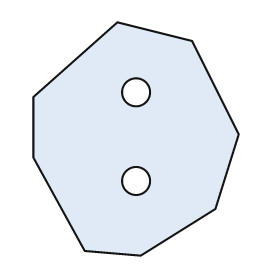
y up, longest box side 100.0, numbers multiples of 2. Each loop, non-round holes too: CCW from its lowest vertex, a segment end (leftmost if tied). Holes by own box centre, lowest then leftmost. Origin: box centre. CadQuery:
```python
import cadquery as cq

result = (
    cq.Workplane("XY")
    .moveTo(2.0, -50.0)
    .lineTo(34.0, -30.0)
    .lineTo(44.0, 2.0)
    .lineTo(24.0, 42.0)
    .lineTo(-8.0, 50.0)
    .lineTo(-44.0, 18.0)
    .lineTo(-44.0, -8.0)
    .lineTo(-22.0, -48.0)
    .close()
    .moveTo(0.0, -18.0)
    .circle(6.0)
    .moveTo(0.0, 20.0)
    .circle(6.0)
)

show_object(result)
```